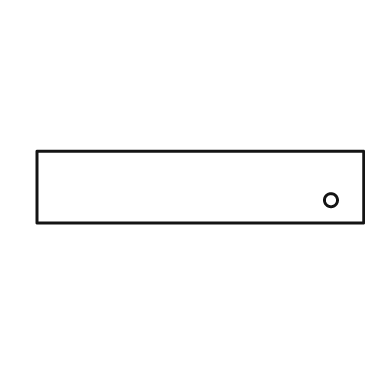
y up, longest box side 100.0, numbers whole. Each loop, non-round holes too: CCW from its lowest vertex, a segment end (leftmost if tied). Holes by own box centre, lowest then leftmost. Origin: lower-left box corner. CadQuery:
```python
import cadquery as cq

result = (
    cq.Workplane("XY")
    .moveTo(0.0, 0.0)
    .lineTo(100.0, 0.0)
    .lineTo(100.0, 22.0)
    .lineTo(0.0, 22.0)
    .close()
    .moveTo(90.0, 7.0)
    .circle(2.0)
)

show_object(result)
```